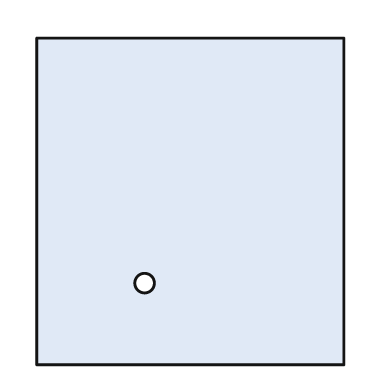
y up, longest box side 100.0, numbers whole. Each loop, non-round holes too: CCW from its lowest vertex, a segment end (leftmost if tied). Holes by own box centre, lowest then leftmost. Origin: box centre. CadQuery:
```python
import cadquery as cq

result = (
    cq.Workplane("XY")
    .moveTo(-47.0, -50.0)
    .lineTo(47.0, -50.0)
    .lineTo(47.0, 50.0)
    .lineTo(-47.0, 50.0)
    .close()
    .moveTo(-14.0, -25.0)
    .circle(3.0)
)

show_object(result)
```